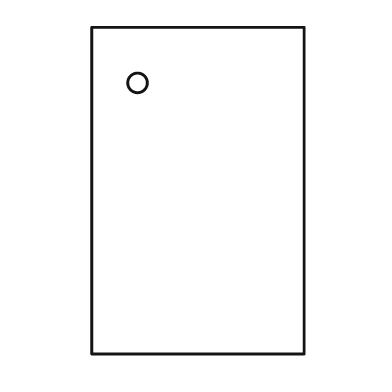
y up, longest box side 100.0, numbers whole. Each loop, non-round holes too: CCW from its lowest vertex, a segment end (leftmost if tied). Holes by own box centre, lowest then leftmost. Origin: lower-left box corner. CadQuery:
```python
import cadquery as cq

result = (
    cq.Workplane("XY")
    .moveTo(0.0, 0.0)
    .lineTo(65.0, 0.0)
    .lineTo(65.0, 100.0)
    .lineTo(0.0, 100.0)
    .close()
    .moveTo(14.0, 83.0)
    .circle(3.0)
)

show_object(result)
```